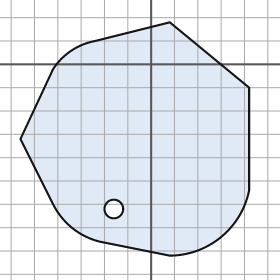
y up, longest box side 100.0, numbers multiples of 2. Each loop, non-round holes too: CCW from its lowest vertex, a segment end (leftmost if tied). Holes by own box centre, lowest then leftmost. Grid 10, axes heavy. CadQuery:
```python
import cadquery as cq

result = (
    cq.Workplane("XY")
    .moveTo(8.0, -82.0)
    .threePointArc((30.0, -74.0), (42.0, -54.0))
    .lineTo(42.0, -10.0)
    .lineTo(8.0, 18.0)
    .lineTo(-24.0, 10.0)
    .threePointArc((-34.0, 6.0), (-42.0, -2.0))
    .lineTo(-56.0, -32.0)
    .lineTo(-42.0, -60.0)
    .threePointArc((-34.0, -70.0), (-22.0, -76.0))
    .close()
    .moveTo(-16.0, -62.0)
    .circle(4.0)
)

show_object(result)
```